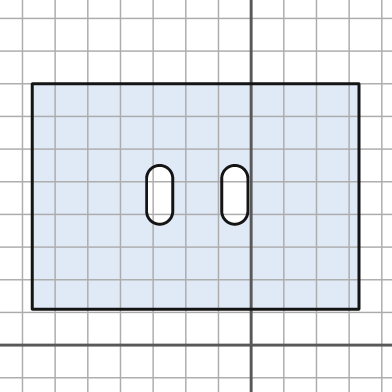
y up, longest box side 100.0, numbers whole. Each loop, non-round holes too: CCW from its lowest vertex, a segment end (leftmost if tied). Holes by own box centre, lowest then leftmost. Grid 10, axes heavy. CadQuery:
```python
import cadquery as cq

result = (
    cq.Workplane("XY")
    .moveTo(-67.0, 11.0)
    .lineTo(33.0, 11.0)
    .lineTo(33.0, 80.0)
    .lineTo(-67.0, 80.0)
    .close()
    .moveTo(-32.0, 41.0)
    .threePointArc((-28.0, 37.0), (-24.0, 41.0))
    .lineTo(-24.0, 51.0)
    .threePointArc((-28.0, 55.0), (-32.0, 51.0))
    .close()
    .moveTo(-9.0, 41.0)
    .threePointArc((-5.0, 37.0), (-1.0, 41.0))
    .lineTo(-1.0, 51.0)
    .threePointArc((-5.0, 55.0), (-9.0, 51.0))
    .close()
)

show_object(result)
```